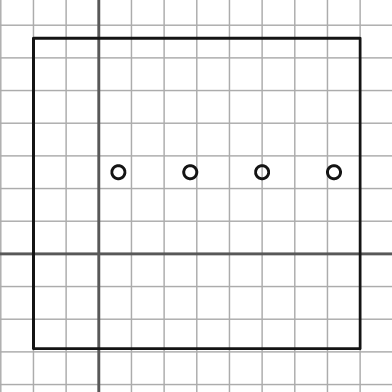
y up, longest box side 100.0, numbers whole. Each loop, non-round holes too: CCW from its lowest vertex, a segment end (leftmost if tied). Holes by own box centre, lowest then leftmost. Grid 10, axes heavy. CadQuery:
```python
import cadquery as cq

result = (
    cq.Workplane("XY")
    .moveTo(-20.0, -29.0)
    .lineTo(80.0, -29.0)
    .lineTo(80.0, 66.0)
    .lineTo(-20.0, 66.0)
    .close()
    .moveTo(6.0, 25.0)
    .circle(2.0)
    .moveTo(28.0, 25.0)
    .circle(2.0)
    .moveTo(50.0, 25.0)
    .circle(2.0)
    .moveTo(72.0, 25.0)
    .circle(2.0)
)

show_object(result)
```